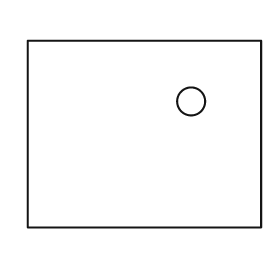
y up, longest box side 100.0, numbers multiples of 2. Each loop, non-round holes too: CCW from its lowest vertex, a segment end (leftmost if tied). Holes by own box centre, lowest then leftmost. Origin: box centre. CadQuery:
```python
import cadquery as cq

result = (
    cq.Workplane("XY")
    .moveTo(-50.0, -40.0)
    .lineTo(50.0, -40.0)
    .lineTo(50.0, 40.0)
    .lineTo(-50.0, 40.0)
    .close()
    .moveTo(20.0, 14.0)
    .circle(6.0)
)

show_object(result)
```